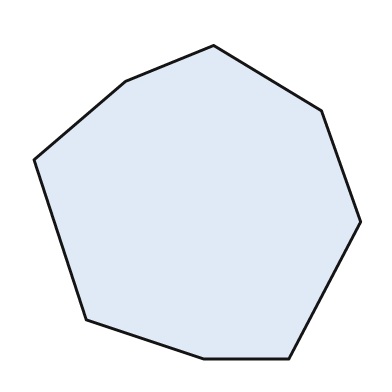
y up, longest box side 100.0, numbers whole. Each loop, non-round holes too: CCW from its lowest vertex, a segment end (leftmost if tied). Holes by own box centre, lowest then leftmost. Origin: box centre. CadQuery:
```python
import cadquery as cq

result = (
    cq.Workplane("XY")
    .moveTo(2.0, -48.0)
    .lineTo(28.0, -48.0)
    .lineTo(50.0, -6.0)
    .lineTo(38.0, 28.0)
    .lineTo(5.0, 48.0)
    .lineTo(-22.0, 37.0)
    .lineTo(-50.0, 13.0)
    .lineTo(-34.0, -36.0)
    .close()
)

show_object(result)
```